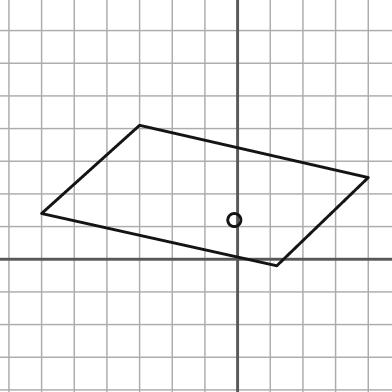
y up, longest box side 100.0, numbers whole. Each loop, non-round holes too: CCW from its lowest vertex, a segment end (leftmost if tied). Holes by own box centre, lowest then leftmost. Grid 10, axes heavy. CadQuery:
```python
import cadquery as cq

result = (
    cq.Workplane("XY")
    .moveTo(12.0, -2.0)
    .lineTo(40.0, 25.0)
    .lineTo(-30.0, 41.0)
    .lineTo(-60.0, 14.0)
    .close()
    .moveTo(-1.0, 12.0)
    .circle(2.0)
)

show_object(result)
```